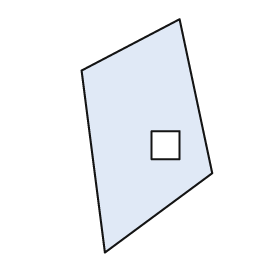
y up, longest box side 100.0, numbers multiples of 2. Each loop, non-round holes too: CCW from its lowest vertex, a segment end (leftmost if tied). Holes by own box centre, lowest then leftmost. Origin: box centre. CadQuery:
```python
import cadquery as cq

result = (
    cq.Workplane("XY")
    .moveTo(-18.0, -50.0)
    .lineTo(28.0, -16.0)
    .lineTo(14.0, 50.0)
    .lineTo(-28.0, 28.0)
    .close()
    .moveTo(2.0, -10.0)
    .lineTo(14.0, -10.0)
    .lineTo(14.0, 2.0)
    .lineTo(2.0, 2.0)
    .close()
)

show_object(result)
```